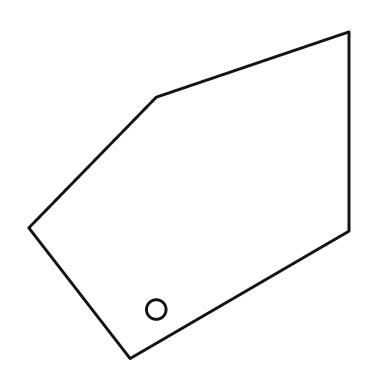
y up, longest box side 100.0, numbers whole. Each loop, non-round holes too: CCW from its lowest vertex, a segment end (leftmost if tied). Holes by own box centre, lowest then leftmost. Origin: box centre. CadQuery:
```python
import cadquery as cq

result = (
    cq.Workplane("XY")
    .moveTo(-18.0, -50.0)
    .lineTo(49.0, -11.0)
    .lineTo(49.0, 50.0)
    .lineTo(-10.0, 30.0)
    .lineTo(-49.0, -10.0)
    .close()
    .moveTo(-10.0, -35.0)
    .circle(3.0)
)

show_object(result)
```